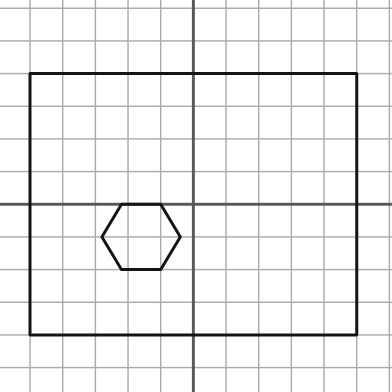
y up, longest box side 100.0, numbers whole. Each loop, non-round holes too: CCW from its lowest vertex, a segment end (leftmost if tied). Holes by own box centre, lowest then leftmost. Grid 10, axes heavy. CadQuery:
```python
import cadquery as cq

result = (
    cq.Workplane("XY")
    .moveTo(-50.0, -40.0)
    .lineTo(50.0, -40.0)
    .lineTo(50.0, 40.0)
    .lineTo(-50.0, 40.0)
    .close()
    .moveTo(-22.0, -20.0)
    .lineTo(-10.0, -20.0)
    .lineTo(-4.0, -10.0)
    .lineTo(-10.0, 0.0)
    .lineTo(-22.0, 0.0)
    .lineTo(-28.0, -10.0)
    .close()
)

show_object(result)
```